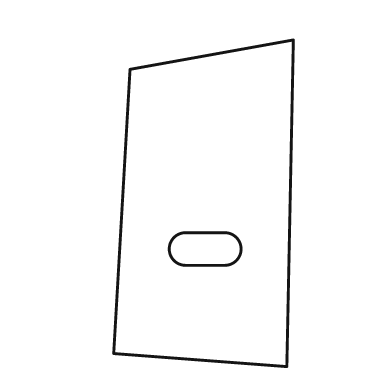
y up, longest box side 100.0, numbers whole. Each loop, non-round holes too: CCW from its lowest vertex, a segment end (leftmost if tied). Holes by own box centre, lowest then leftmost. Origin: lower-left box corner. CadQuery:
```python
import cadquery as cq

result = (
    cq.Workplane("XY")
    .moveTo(53.0, 0.0)
    .lineTo(55.0, 100.0)
    .lineTo(5.0, 91.0)
    .lineTo(0.0, 4.0)
    .close()
    .moveTo(22.0, 31.0)
    .lineTo(34.0, 31.0)
    .threePointArc((39.0, 36.0), (34.0, 41.0))
    .lineTo(22.0, 41.0)
    .threePointArc((17.0, 36.0), (22.0, 31.0))
    .close()
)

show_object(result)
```